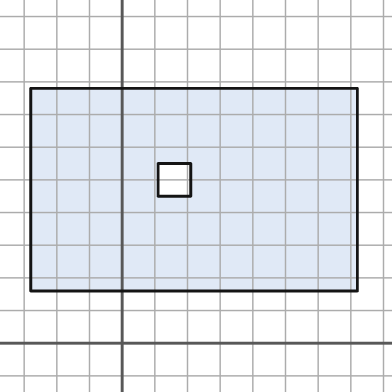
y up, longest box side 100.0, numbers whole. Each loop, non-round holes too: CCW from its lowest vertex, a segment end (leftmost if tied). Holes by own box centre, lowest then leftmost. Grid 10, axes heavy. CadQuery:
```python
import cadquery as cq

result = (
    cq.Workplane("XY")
    .moveTo(-28.0, 16.0)
    .lineTo(72.0, 16.0)
    .lineTo(72.0, 78.0)
    .lineTo(-28.0, 78.0)
    .close()
    .moveTo(11.0, 45.0)
    .lineTo(21.0, 45.0)
    .lineTo(21.0, 55.0)
    .lineTo(11.0, 55.0)
    .close()
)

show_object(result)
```